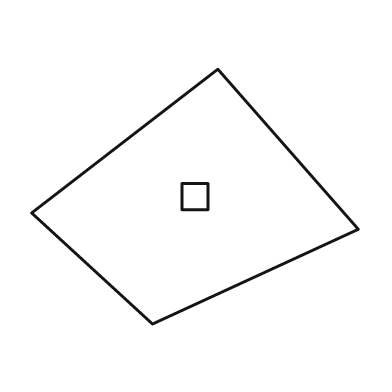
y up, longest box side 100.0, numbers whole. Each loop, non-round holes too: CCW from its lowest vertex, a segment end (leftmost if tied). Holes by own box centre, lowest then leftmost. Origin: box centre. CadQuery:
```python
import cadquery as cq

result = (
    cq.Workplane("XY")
    .moveTo(-13.0, -39.0)
    .lineTo(50.0, -10.0)
    .lineTo(7.0, 39.0)
    .lineTo(-50.0, -5.0)
    .close()
    .moveTo(-4.0, -4.0)
    .lineTo(4.0, -4.0)
    .lineTo(4.0, 4.0)
    .lineTo(-4.0, 4.0)
    .close()
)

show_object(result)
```